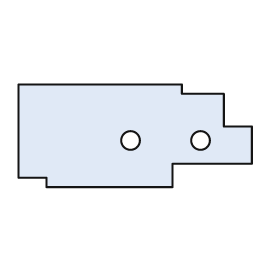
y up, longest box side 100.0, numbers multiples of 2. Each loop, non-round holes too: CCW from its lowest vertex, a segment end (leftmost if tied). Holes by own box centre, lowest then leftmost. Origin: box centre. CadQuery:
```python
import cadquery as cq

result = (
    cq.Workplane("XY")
    .moveTo(-38.0, -22.0)
    .lineTo(16.0, -22.0)
    .lineTo(16.0, -12.0)
    .lineTo(50.0, -12.0)
    .lineTo(50.0, 4.0)
    .lineTo(38.0, 4.0)
    .lineTo(38.0, 18.0)
    .lineTo(20.0, 18.0)
    .lineTo(20.0, 22.0)
    .lineTo(-50.0, 22.0)
    .lineTo(-50.0, -18.0)
    .lineTo(-38.0, -18.0)
    .close()
    .moveTo(-2.0, -2.0)
    .circle(4.0)
    .moveTo(28.0, -2.0)
    .circle(4.0)
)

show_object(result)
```